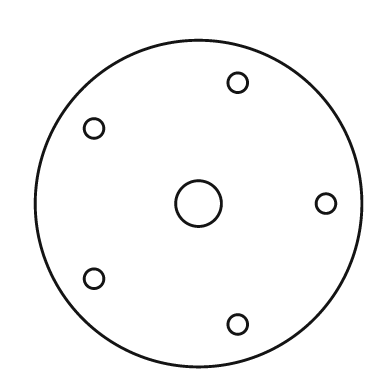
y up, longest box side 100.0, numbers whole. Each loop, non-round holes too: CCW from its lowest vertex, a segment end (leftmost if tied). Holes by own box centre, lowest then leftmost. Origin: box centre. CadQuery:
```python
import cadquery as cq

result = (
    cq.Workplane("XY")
    .moveTo(0.0, 0.0)
    .circle(50.0)
    .moveTo(12.0, -37.0)
    .circle(3.0)
    .moveTo(-32.0, -23.0)
    .circle(3.0)
    .moveTo(0.0, 0.0)
    .circle(7.0)
    .moveTo(39.0, 0.0)
    .circle(3.0)
    .moveTo(-32.0, 23.0)
    .circle(3.0)
    .moveTo(12.0, 37.0)
    .circle(3.0)
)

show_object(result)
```